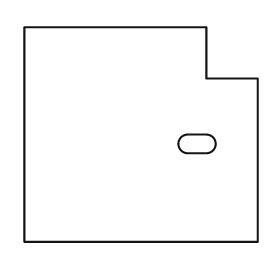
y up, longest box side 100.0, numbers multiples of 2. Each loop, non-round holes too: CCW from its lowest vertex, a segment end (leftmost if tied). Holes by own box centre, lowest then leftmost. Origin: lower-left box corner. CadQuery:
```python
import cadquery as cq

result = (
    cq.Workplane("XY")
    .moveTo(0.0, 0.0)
    .lineTo(100.0, 0.0)
    .lineTo(100.0, 70.0)
    .lineTo(78.0, 70.0)
    .lineTo(78.0, 92.0)
    .lineTo(0.0, 92.0)
    .close()
    .moveTo(70.0, 38.0)
    .lineTo(78.0, 38.0)
    .threePointArc((82.0, 42.0), (78.0, 46.0))
    .lineTo(70.0, 46.0)
    .threePointArc((66.0, 42.0), (70.0, 38.0))
    .close()
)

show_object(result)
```